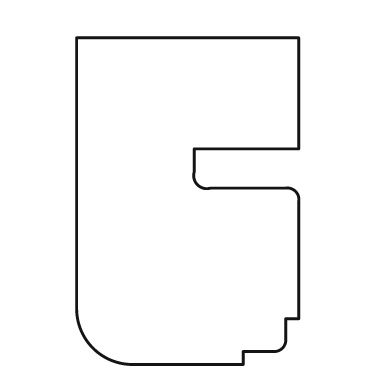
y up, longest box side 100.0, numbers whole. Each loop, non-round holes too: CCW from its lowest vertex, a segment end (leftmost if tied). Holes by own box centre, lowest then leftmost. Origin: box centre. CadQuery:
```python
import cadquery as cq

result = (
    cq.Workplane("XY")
    .moveTo(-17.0, -50.0)
    .lineTo(17.0, -50.0)
    .lineTo(17.0, -46.0)
    .lineTo(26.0, -46.0)
    .threePointArc((29.0, -45.0), (30.0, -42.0))
    .lineTo(30.0, -36.0)
    .lineTo(34.0, -36.0)
    .lineTo(34.0, 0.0)
    .threePointArc((33.0, 3.0), (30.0, 4.0))
    .lineTo(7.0, 4.0)
    .threePointArc((3.0, 5.0), (2.0, 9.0))
    .lineTo(2.0, 16.0)
    .lineTo(34.0, 16.0)
    .lineTo(34.0, 50.0)
    .lineTo(-34.0, 50.0)
    .lineTo(-34.0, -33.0)
    .threePointArc((-29.0, -45.0), (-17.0, -50.0))
    .close()
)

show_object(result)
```